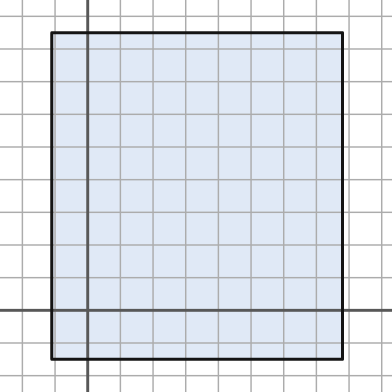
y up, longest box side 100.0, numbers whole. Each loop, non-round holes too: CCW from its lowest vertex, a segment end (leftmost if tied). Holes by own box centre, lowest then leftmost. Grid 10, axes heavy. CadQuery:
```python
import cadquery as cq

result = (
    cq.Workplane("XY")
    .moveTo(-11.0, -15.0)
    .lineTo(78.0, -15.0)
    .lineTo(78.0, 85.0)
    .lineTo(-11.0, 85.0)
    .close()
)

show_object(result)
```